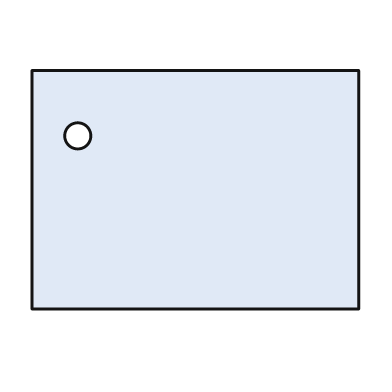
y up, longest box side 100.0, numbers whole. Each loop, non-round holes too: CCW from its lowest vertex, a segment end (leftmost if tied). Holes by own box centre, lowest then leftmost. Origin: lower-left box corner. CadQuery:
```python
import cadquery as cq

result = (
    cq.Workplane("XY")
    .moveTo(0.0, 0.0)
    .lineTo(100.0, 0.0)
    .lineTo(100.0, 73.0)
    .lineTo(0.0, 73.0)
    .close()
    .moveTo(14.0, 53.0)
    .circle(4.0)
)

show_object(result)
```